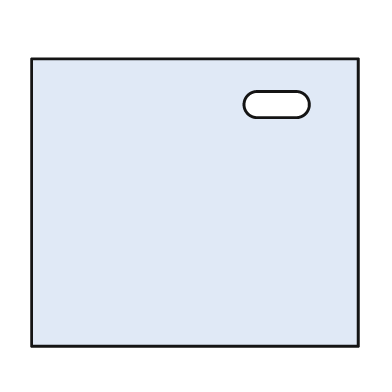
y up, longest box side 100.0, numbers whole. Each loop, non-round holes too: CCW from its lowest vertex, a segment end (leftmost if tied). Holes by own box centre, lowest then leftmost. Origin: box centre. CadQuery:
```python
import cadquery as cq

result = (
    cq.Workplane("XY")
    .moveTo(-50.0, -44.0)
    .lineTo(50.0, -44.0)
    .lineTo(50.0, 44.0)
    .lineTo(-50.0, 44.0)
    .close()
    .moveTo(19.0, 26.0)
    .lineTo(31.0, 26.0)
    .threePointArc((35.0, 30.0), (31.0, 34.0))
    .lineTo(19.0, 34.0)
    .threePointArc((15.0, 30.0), (19.0, 26.0))
    .close()
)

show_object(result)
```